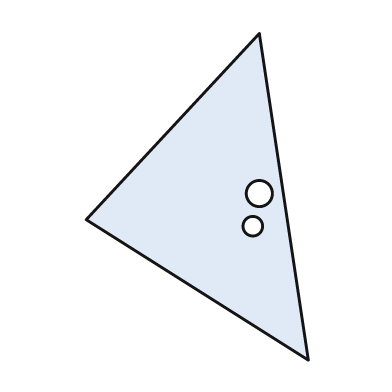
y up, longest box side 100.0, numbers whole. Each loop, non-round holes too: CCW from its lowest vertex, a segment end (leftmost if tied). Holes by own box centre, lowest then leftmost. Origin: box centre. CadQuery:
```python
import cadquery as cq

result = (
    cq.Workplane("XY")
    .moveTo(34.0, -50.0)
    .lineTo(19.0, 50.0)
    .lineTo(-34.0, -7.0)
    .close()
    .moveTo(17.0, -9.0)
    .circle(3.0)
    .moveTo(19.0, 1.0)
    .circle(4.0)
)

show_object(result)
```